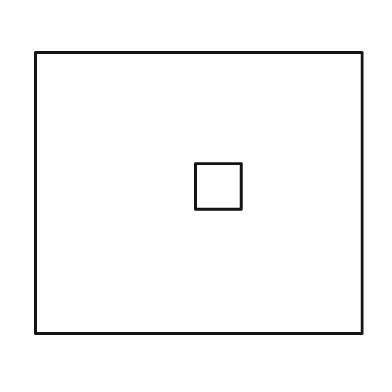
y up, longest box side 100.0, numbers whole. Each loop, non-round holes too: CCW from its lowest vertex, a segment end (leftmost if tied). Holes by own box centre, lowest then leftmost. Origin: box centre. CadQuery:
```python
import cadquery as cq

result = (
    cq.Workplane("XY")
    .moveTo(-50.0, -43.0)
    .lineTo(50.0, -43.0)
    .lineTo(50.0, 43.0)
    .lineTo(-50.0, 43.0)
    .close()
    .moveTo(-1.0, -5.0)
    .lineTo(13.0, -5.0)
    .lineTo(13.0, 9.0)
    .lineTo(-1.0, 9.0)
    .close()
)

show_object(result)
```